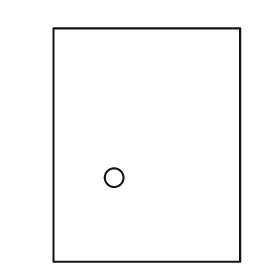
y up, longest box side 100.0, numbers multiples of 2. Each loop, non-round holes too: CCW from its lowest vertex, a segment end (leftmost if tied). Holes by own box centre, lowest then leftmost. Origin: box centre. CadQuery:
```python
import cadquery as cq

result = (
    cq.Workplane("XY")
    .moveTo(-40.0, -50.0)
    .lineTo(40.0, -50.0)
    .lineTo(40.0, 50.0)
    .lineTo(-40.0, 50.0)
    .close()
    .moveTo(-14.0, -14.0)
    .circle(4.0)
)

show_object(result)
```